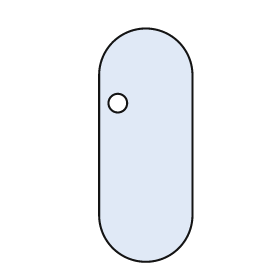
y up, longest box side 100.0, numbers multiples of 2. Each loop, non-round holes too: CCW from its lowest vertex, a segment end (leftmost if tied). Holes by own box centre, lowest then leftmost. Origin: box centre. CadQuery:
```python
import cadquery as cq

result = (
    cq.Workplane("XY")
    .moveTo(-20.0, -30.0)
    .threePointArc((0.0, -50.0), (20.0, -30.0))
    .lineTo(20.0, 30.0)
    .threePointArc((0.0, 50.0), (-20.0, 30.0))
    .close()
    .moveTo(-12.0, 18.0)
    .circle(4.0)
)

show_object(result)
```